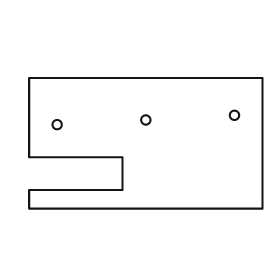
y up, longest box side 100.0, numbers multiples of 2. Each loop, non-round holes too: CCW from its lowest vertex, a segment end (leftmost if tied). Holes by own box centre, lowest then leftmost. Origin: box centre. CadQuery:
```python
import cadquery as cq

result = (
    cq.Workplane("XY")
    .moveTo(-50.0, -28.0)
    .lineTo(50.0, -28.0)
    .lineTo(50.0, 28.0)
    .lineTo(-50.0, 28.0)
    .lineTo(-50.0, -6.0)
    .lineTo(-10.0, -6.0)
    .lineTo(-10.0, -20.0)
    .lineTo(-50.0, -20.0)
    .close()
    .moveTo(-38.0, 8.0)
    .circle(2.0)
    .moveTo(0.0, 10.0)
    .circle(2.0)
    .moveTo(38.0, 12.0)
    .circle(2.0)
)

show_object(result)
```